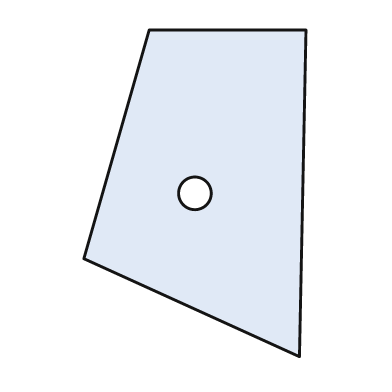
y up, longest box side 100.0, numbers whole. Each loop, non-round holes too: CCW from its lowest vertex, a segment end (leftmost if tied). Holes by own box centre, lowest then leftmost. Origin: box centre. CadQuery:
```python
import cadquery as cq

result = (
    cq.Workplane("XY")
    .moveTo(32.0, -50.0)
    .lineTo(34.0, 50.0)
    .lineTo(-14.0, 50.0)
    .lineTo(-34.0, -20.0)
    .close()
    .moveTo(0.0, 0.0)
    .circle(5.0)
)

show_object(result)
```